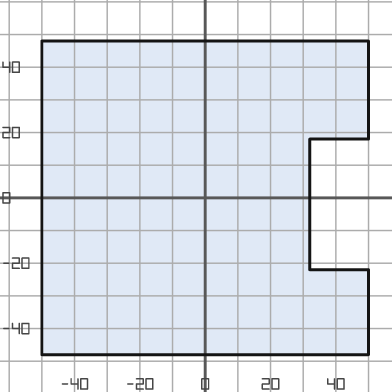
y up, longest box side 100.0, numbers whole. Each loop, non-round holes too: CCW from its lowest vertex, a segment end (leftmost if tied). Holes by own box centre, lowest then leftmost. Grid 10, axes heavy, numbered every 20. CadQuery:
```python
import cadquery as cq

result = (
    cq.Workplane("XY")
    .moveTo(-50.0, -48.0)
    .lineTo(50.0, -48.0)
    .lineTo(50.0, -22.0)
    .lineTo(32.0, -22.0)
    .lineTo(32.0, 18.0)
    .lineTo(50.0, 18.0)
    .lineTo(50.0, 48.0)
    .lineTo(-50.0, 48.0)
    .close()
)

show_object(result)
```